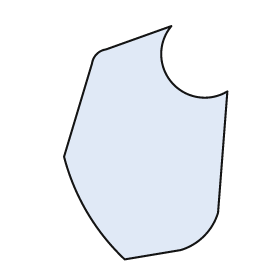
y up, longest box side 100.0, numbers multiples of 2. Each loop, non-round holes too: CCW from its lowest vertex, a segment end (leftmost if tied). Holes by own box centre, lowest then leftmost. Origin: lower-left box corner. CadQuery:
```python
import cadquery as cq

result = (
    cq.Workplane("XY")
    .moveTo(26.0, 0.0)
    .lineTo(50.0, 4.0)
    .threePointArc((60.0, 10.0), (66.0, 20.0))
    .lineTo(70.0, 72.0)
    .threePointArc((46.0, 76.0), (46.0, 100.0))
    .lineTo(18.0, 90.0)
    .threePointArc((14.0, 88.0), (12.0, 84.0))
    .lineTo(0.0, 44.0)
    .threePointArc((10.0, 20.0), (26.0, 0.0))
    .close()
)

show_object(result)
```